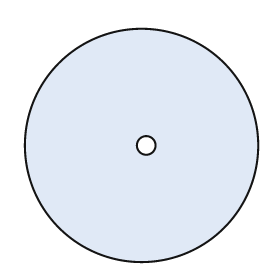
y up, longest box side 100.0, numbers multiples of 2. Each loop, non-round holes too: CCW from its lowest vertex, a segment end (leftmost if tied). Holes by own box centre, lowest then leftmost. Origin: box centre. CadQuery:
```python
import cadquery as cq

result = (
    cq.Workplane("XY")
    .moveTo(0.0, 0.0)
    .circle(50.0)
    .moveTo(2.0, 0.0)
    .circle(4.0)
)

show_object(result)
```